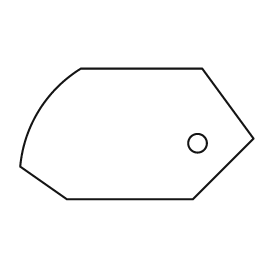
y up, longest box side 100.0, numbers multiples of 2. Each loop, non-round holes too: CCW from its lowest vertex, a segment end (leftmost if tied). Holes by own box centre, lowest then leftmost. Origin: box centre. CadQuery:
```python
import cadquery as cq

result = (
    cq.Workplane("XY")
    .moveTo(-30.0, -28.0)
    .lineTo(24.0, -28.0)
    .lineTo(50.0, -2.0)
    .lineTo(28.0, 28.0)
    .lineTo(-24.0, 28.0)
    .threePointArc((-42.0, 10.0), (-50.0, -14.0))
    .close()
    .moveTo(26.0, -4.0)
    .circle(4.0)
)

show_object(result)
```